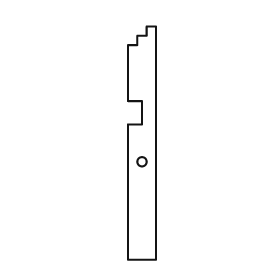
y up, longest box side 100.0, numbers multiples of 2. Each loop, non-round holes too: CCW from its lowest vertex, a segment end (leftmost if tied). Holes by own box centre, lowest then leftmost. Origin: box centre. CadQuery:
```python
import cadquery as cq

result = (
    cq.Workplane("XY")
    .moveTo(-6.0, -50.0)
    .lineTo(6.0, -50.0)
    .lineTo(6.0, 50.0)
    .lineTo(2.0, 50.0)
    .lineTo(2.0, 46.0)
    .lineTo(-2.0, 46.0)
    .lineTo(-2.0, 42.0)
    .lineTo(-6.0, 42.0)
    .lineTo(-6.0, 18.0)
    .lineTo(0.0, 18.0)
    .lineTo(0.0, 8.0)
    .lineTo(-6.0, 8.0)
    .close()
    .moveTo(0.0, -8.0)
    .circle(2.0)
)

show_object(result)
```